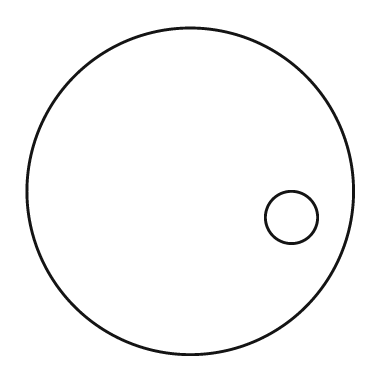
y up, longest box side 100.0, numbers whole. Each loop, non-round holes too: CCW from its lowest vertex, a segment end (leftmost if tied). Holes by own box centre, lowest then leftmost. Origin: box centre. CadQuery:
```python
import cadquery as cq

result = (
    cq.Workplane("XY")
    .moveTo(0.0, 0.0)
    .circle(50.0)
    .moveTo(31.0, -8.0)
    .circle(8.0)
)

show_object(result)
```